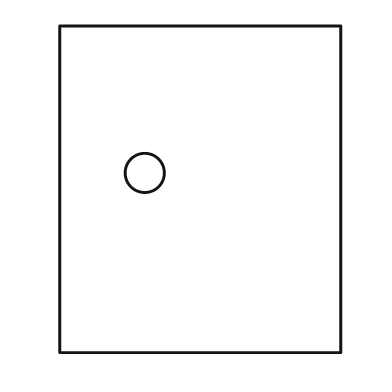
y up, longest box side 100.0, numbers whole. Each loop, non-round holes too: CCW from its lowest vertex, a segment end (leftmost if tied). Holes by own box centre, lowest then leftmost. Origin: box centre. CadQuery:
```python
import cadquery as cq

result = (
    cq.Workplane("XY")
    .moveTo(-43.0, -50.0)
    .lineTo(43.0, -50.0)
    .lineTo(43.0, 50.0)
    .lineTo(-43.0, 50.0)
    .close()
    .moveTo(-17.0, 5.0)
    .circle(6.0)
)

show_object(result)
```